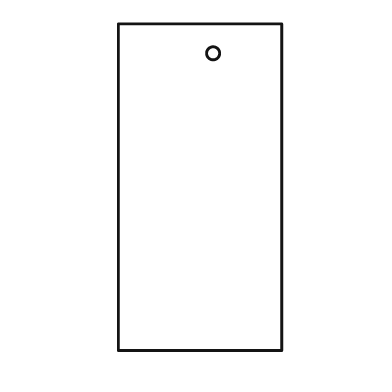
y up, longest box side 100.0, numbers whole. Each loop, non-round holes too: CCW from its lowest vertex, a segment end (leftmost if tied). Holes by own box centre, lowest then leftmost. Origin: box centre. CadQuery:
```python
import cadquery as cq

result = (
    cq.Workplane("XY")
    .moveTo(-25.0, -50.0)
    .lineTo(25.0, -50.0)
    .lineTo(25.0, 50.0)
    .lineTo(-25.0, 50.0)
    .close()
    .moveTo(4.0, 41.0)
    .circle(2.0)
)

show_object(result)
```